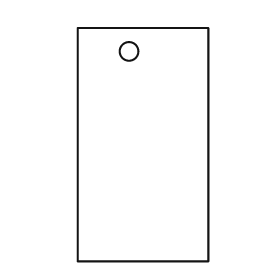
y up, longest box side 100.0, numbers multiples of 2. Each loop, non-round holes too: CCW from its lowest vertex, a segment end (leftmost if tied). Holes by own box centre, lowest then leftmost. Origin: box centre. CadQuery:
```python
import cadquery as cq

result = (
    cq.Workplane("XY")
    .moveTo(-28.0, -50.0)
    .lineTo(28.0, -50.0)
    .lineTo(28.0, 50.0)
    .lineTo(-28.0, 50.0)
    .close()
    .moveTo(-6.0, 40.0)
    .circle(4.0)
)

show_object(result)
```